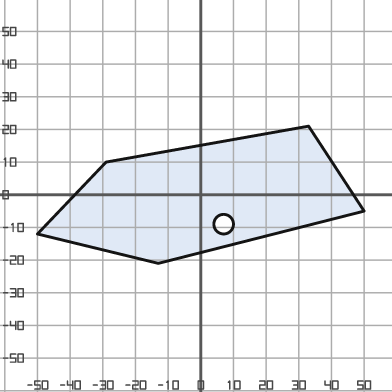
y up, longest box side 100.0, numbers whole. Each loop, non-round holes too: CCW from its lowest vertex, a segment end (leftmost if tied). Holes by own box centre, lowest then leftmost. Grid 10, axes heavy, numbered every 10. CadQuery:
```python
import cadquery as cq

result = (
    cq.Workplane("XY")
    .moveTo(-13.0, -21.0)
    .lineTo(50.0, -5.0)
    .lineTo(33.0, 21.0)
    .lineTo(-29.0, 10.0)
    .lineTo(-50.0, -12.0)
    .close()
    .moveTo(7.0, -9.0)
    .circle(3.0)
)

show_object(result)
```